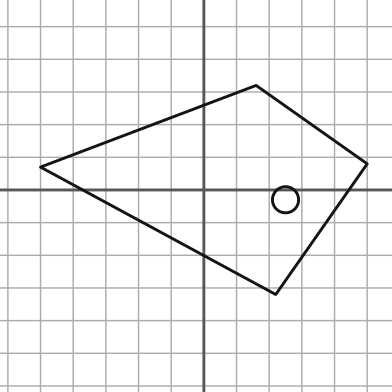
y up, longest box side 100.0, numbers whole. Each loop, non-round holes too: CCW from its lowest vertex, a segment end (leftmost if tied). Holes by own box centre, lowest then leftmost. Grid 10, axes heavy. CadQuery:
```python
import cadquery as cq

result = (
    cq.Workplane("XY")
    .moveTo(22.0, -32.0)
    .lineTo(50.0, 8.0)
    .lineTo(16.0, 32.0)
    .lineTo(-50.0, 7.0)
    .close()
    .moveTo(25.0, -3.0)
    .circle(4.0)
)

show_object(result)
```